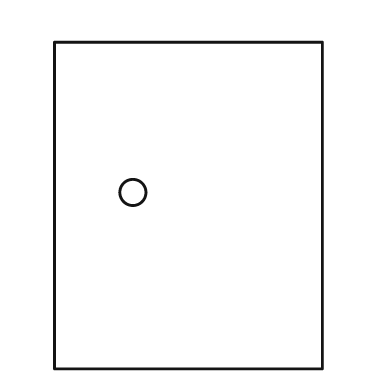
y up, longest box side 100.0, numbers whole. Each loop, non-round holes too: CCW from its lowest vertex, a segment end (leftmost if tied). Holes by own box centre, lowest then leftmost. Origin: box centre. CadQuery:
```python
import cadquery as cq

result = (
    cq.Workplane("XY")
    .moveTo(-41.0, -50.0)
    .lineTo(41.0, -50.0)
    .lineTo(41.0, 50.0)
    .lineTo(-41.0, 50.0)
    .close()
    .moveTo(-17.0, 4.0)
    .circle(4.0)
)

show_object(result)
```